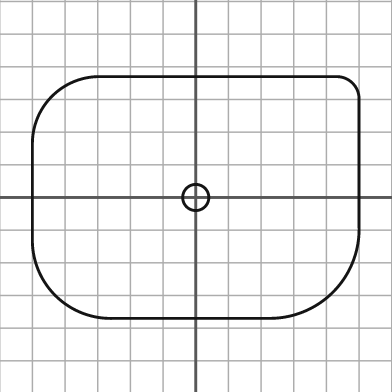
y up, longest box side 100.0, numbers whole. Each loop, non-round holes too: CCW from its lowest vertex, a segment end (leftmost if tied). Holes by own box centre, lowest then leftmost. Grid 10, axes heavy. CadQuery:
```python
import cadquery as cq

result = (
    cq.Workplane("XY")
    .moveTo(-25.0, -37.0)
    .lineTo(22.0, -37.0)
    .threePointArc((42.0, -29.0), (50.0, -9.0))
    .lineTo(50.0, 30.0)
    .threePointArc((48.0, 35.0), (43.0, 37.0))
    .lineTo(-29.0, 37.0)
    .threePointArc((-44.0, 31.0), (-50.0, 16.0))
    .lineTo(-50.0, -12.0)
    .threePointArc((-43.0, -30.0), (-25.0, -37.0))
    .close()
    .moveTo(0.0, 0.0)
    .circle(4.0)
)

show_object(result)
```